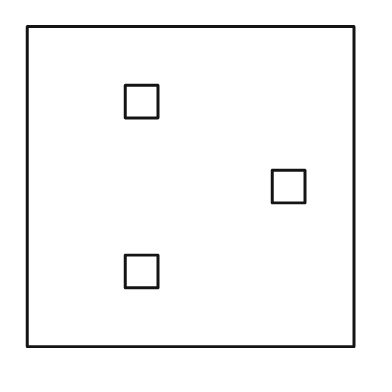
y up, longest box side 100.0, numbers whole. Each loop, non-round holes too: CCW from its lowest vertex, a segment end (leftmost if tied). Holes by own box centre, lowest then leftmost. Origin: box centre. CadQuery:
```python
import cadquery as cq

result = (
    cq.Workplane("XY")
    .moveTo(-50.0, -49.0)
    .lineTo(50.0, -49.0)
    .lineTo(50.0, 49.0)
    .lineTo(-50.0, 49.0)
    .close()
    .moveTo(-20.0, -31.0)
    .lineTo(-10.0, -31.0)
    .lineTo(-10.0, -21.0)
    .lineTo(-20.0, -21.0)
    .close()
    .moveTo(25.0, -5.0)
    .lineTo(35.0, -5.0)
    .lineTo(35.0, 5.0)
    .lineTo(25.0, 5.0)
    .close()
    .moveTo(-20.0, 21.0)
    .lineTo(-10.0, 21.0)
    .lineTo(-10.0, 31.0)
    .lineTo(-20.0, 31.0)
    .close()
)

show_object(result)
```